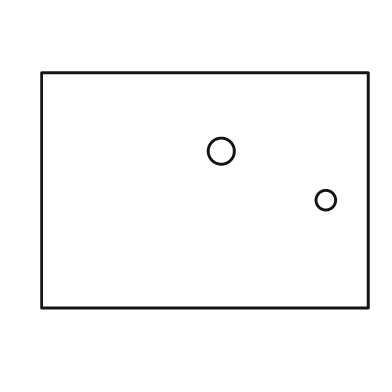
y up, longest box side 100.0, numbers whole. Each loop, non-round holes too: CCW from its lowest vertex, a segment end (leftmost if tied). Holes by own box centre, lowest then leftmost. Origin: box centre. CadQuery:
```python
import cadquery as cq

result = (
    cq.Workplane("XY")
    .moveTo(-50.0, -36.0)
    .lineTo(50.0, -36.0)
    .lineTo(50.0, 36.0)
    .lineTo(-50.0, 36.0)
    .close()
    .moveTo(37.0, -3.0)
    .circle(3.0)
    .moveTo(5.0, 12.0)
    .circle(4.0)
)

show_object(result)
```